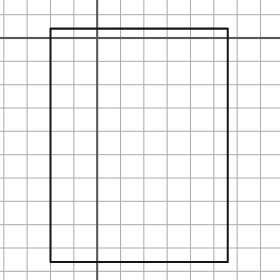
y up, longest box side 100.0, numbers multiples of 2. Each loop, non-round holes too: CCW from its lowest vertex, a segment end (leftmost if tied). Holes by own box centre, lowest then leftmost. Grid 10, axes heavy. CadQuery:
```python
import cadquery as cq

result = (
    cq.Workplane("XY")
    .moveTo(-20.0, -96.0)
    .lineTo(56.0, -96.0)
    .lineTo(56.0, 4.0)
    .lineTo(-20.0, 4.0)
    .close()
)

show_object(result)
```